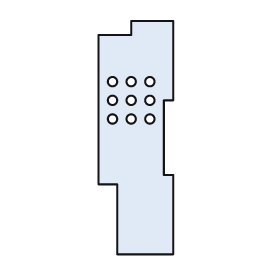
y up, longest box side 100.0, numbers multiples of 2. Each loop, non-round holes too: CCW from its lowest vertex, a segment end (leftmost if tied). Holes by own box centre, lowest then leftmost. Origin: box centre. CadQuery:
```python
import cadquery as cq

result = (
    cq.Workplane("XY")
    .moveTo(-8.0, -50.0)
    .lineTo(16.0, -50.0)
    .lineTo(16.0, -16.0)
    .lineTo(12.0, -16.0)
    .lineTo(12.0, 16.0)
    .lineTo(16.0, 16.0)
    .lineTo(16.0, 50.0)
    .lineTo(-2.0, 50.0)
    .lineTo(-2.0, 44.0)
    .lineTo(-16.0, 44.0)
    .lineTo(-16.0, -20.0)
    .lineTo(-8.0, -20.0)
    .close()
    .moveTo(-10.0, 8.0)
    .circle(2.0)
    .moveTo(-2.0, 8.0)
    .circle(2.0)
    .moveTo(6.0, 8.0)
    .circle(2.0)
    .moveTo(-10.0, 16.0)
    .circle(2.0)
    .moveTo(-2.0, 16.0)
    .circle(2.0)
    .moveTo(6.0, 16.0)
    .circle(2.0)
    .moveTo(-10.0, 24.0)
    .circle(2.0)
    .moveTo(-2.0, 24.0)
    .circle(2.0)
    .moveTo(6.0, 24.0)
    .circle(2.0)
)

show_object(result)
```